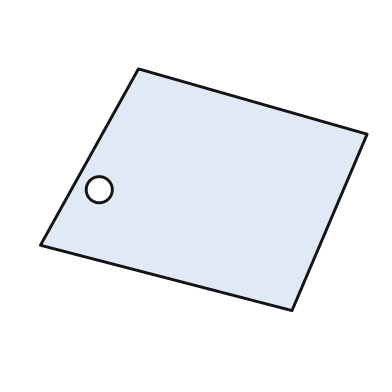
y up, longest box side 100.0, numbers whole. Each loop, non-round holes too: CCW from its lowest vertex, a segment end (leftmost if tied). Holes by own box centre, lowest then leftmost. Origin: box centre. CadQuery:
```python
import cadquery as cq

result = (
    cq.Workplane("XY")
    .moveTo(27.0, -37.0)
    .lineTo(50.0, 17.0)
    .lineTo(-20.0, 37.0)
    .lineTo(-50.0, -17.0)
    .close()
    .moveTo(-32.0, 0.0)
    .circle(4.0)
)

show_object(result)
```